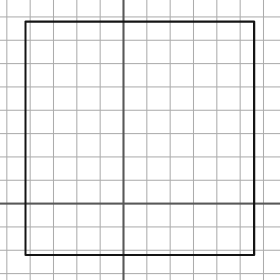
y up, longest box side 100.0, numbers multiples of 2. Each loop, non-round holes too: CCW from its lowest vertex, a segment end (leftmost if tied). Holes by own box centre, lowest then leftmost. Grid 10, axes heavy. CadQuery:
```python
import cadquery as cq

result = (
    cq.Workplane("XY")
    .moveTo(-42.0, -22.0)
    .lineTo(56.0, -22.0)
    .lineTo(56.0, 78.0)
    .lineTo(-42.0, 78.0)
    .close()
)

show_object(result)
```